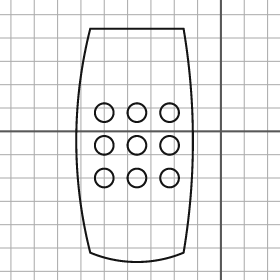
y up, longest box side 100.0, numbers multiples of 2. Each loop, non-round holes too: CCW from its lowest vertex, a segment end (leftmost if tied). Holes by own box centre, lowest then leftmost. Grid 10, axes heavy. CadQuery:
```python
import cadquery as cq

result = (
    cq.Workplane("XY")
    .moveTo(-56.0, -52.0)
    .threePointArc((-36.0, -56.0), (-16.0, -52.0))
    .threePointArc((-12.0, -4.0), (-16.0, 44.0))
    .lineTo(-56.0, 44.0)
    .threePointArc((-62.0, -4.0), (-56.0, -52.0))
    .close()
    .moveTo(-50.0, -20.0)
    .circle(4.0)
    .moveTo(-36.0, -20.0)
    .circle(4.0)
    .moveTo(-22.0, -20.0)
    .circle(4.0)
    .moveTo(-50.0, -6.0)
    .circle(4.0)
    .moveTo(-36.0, -6.0)
    .circle(4.0)
    .moveTo(-22.0, -6.0)
    .circle(4.0)
    .moveTo(-50.0, 8.0)
    .circle(4.0)
    .moveTo(-36.0, 8.0)
    .circle(4.0)
    .moveTo(-22.0, 8.0)
    .circle(4.0)
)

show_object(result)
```